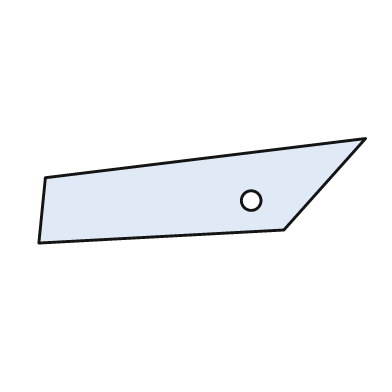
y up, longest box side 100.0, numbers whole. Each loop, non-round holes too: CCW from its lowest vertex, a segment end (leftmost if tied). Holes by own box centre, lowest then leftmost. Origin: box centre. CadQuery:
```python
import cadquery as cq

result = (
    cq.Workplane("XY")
    .moveTo(-50.0, -16.0)
    .lineTo(25.0, -12.0)
    .lineTo(50.0, 16.0)
    .lineTo(-48.0, 4.0)
    .close()
    .moveTo(15.0, -3.0)
    .circle(3.0)
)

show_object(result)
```